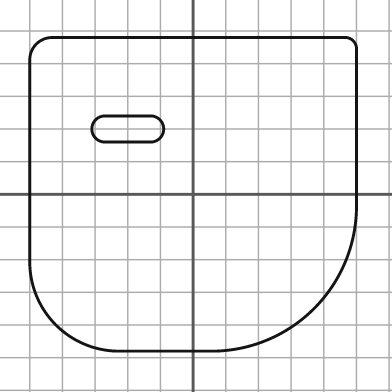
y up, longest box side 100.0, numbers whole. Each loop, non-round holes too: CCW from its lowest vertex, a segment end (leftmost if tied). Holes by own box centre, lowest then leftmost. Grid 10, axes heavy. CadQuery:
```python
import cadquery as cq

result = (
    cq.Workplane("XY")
    .moveTo(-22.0, -48.0)
    .lineTo(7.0, -48.0)
    .threePointArc((37.0, -35.0), (50.0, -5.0))
    .lineTo(50.0, 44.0)
    .threePointArc((49.0, 47.0), (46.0, 48.0))
    .lineTo(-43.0, 48.0)
    .threePointArc((-48.0, 46.0), (-50.0, 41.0))
    .lineTo(-50.0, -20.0)
    .threePointArc((-42.0, -40.0), (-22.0, -48.0))
    .close()
    .moveTo(-27.0, 16.0)
    .lineTo(-13.0, 16.0)
    .threePointArc((-9.0, 20.0), (-13.0, 24.0))
    .lineTo(-27.0, 24.0)
    .threePointArc((-31.0, 20.0), (-27.0, 16.0))
    .close()
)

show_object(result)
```